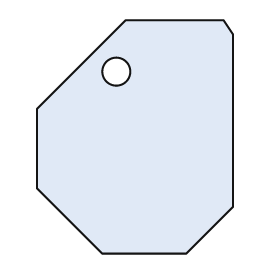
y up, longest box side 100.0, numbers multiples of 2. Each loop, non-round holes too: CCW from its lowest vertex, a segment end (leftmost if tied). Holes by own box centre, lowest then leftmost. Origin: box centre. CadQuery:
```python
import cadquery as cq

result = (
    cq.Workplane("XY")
    .moveTo(-14.0, -50.0)
    .lineTo(22.0, -50.0)
    .lineTo(42.0, -30.0)
    .lineTo(42.0, 44.0)
    .lineTo(38.0, 50.0)
    .lineTo(-4.0, 50.0)
    .lineTo(-42.0, 12.0)
    .lineTo(-42.0, -22.0)
    .close()
    .moveTo(-8.0, 28.0)
    .circle(6.0)
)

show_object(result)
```